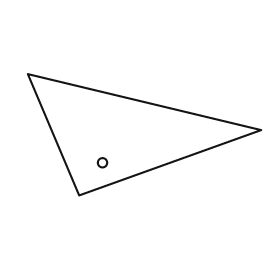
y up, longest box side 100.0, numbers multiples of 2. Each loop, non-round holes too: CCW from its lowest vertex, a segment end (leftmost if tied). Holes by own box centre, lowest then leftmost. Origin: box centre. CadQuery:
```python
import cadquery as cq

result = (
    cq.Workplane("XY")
    .moveTo(-28.0, -26.0)
    .lineTo(50.0, 2.0)
    .lineTo(-50.0, 26.0)
    .close()
    .moveTo(-18.0, -12.0)
    .circle(2.0)
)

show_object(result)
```